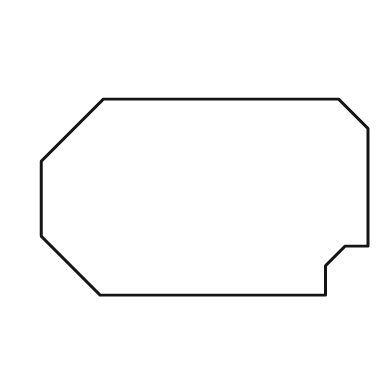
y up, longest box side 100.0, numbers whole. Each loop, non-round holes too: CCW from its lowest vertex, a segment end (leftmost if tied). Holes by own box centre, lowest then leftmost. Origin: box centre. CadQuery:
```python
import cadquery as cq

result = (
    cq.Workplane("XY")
    .moveTo(-32.0, -30.0)
    .lineTo(37.0, -30.0)
    .lineTo(37.0, -21.0)
    .lineTo(43.0, -15.0)
    .lineTo(50.0, -15.0)
    .lineTo(50.0, 21.0)
    .lineTo(41.0, 30.0)
    .lineTo(-31.0, 30.0)
    .lineTo(-50.0, 11.0)
    .lineTo(-50.0, -12.0)
    .close()
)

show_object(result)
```